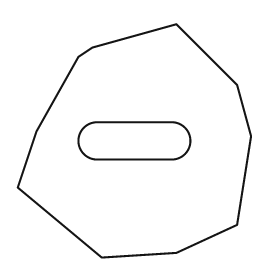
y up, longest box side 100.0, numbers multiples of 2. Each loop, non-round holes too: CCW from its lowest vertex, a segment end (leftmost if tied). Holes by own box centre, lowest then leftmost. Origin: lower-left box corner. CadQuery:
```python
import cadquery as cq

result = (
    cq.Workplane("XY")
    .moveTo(36.0, 0.0)
    .lineTo(68.0, 2.0)
    .lineTo(94.0, 14.0)
    .lineTo(100.0, 52.0)
    .lineTo(94.0, 74.0)
    .lineTo(68.0, 100.0)
    .lineTo(32.0, 90.0)
    .lineTo(26.0, 86.0)
    .lineTo(8.0, 54.0)
    .lineTo(0.0, 30.0)
    .close()
    .moveTo(34.0, 42.0)
    .lineTo(66.0, 42.0)
    .threePointArc((74.0, 50.0), (66.0, 58.0))
    .lineTo(34.0, 58.0)
    .threePointArc((26.0, 50.0), (34.0, 42.0))
    .close()
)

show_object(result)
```